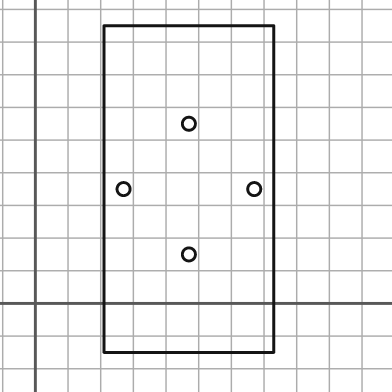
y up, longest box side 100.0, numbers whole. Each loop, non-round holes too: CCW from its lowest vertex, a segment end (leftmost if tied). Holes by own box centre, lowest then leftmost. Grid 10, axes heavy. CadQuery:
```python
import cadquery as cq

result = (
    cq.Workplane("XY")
    .moveTo(21.0, -15.0)
    .lineTo(73.0, -15.0)
    .lineTo(73.0, 85.0)
    .lineTo(21.0, 85.0)
    .close()
    .moveTo(47.0, 15.0)
    .circle(2.0)
    .moveTo(27.0, 35.0)
    .circle(2.0)
    .moveTo(67.0, 35.0)
    .circle(2.0)
    .moveTo(47.0, 55.0)
    .circle(2.0)
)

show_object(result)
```